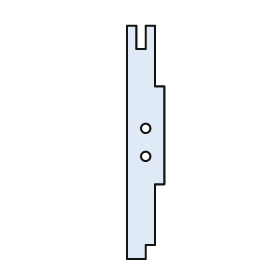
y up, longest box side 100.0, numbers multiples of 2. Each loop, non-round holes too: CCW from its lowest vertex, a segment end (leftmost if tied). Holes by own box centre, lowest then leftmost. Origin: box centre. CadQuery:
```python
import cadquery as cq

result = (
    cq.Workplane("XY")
    .moveTo(-8.0, -50.0)
    .lineTo(0.0, -50.0)
    .lineTo(0.0, -44.0)
    .lineTo(4.0, -44.0)
    .lineTo(4.0, -18.0)
    .lineTo(8.0, -18.0)
    .lineTo(8.0, 24.0)
    .lineTo(4.0, 24.0)
    .lineTo(4.0, 50.0)
    .lineTo(0.0, 50.0)
    .lineTo(0.0, 40.0)
    .lineTo(-4.0, 40.0)
    .lineTo(-4.0, 50.0)
    .lineTo(-8.0, 50.0)
    .close()
    .moveTo(0.0, -6.0)
    .circle(2.0)
    .moveTo(0.0, 6.0)
    .circle(2.0)
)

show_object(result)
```